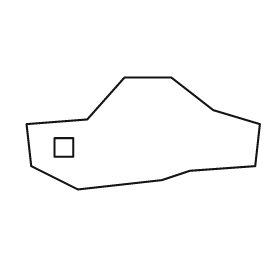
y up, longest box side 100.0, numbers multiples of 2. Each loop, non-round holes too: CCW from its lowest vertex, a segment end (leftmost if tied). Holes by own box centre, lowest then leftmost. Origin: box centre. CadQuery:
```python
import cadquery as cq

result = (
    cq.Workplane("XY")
    .moveTo(-28.0, -24.0)
    .lineTo(8.0, -20.0)
    .lineTo(20.0, -16.0)
    .lineTo(48.0, -14.0)
    .lineTo(50.0, 4.0)
    .lineTo(30.0, 10.0)
    .lineTo(12.0, 24.0)
    .lineTo(-8.0, 24.0)
    .lineTo(-24.0, 6.0)
    .lineTo(-50.0, 4.0)
    .lineTo(-48.0, -14.0)
    .close()
    .moveTo(-38.0, -10.0)
    .lineTo(-30.0, -10.0)
    .lineTo(-30.0, -2.0)
    .lineTo(-38.0, -2.0)
    .close()
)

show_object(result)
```